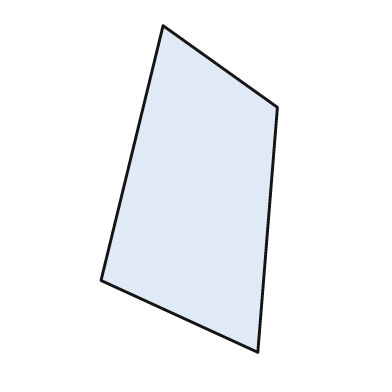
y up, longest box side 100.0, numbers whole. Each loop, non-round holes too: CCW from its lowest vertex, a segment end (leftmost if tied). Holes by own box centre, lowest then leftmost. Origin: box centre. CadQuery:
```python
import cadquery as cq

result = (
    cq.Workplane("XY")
    .moveTo(21.0, -50.0)
    .lineTo(27.0, 25.0)
    .lineTo(-8.0, 50.0)
    .lineTo(-27.0, -28.0)
    .close()
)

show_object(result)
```